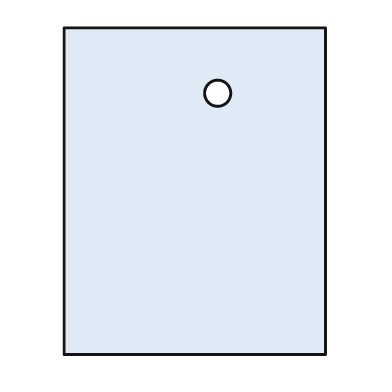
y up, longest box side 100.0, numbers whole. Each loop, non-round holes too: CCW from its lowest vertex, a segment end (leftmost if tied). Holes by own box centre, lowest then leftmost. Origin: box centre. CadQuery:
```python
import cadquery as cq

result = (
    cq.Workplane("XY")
    .moveTo(-40.0, -50.0)
    .lineTo(40.0, -50.0)
    .lineTo(40.0, 50.0)
    .lineTo(-40.0, 50.0)
    .close()
    .moveTo(7.0, 30.0)
    .circle(4.0)
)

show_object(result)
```